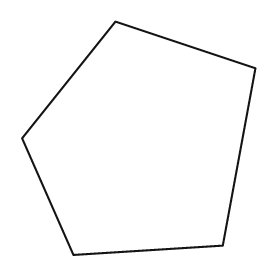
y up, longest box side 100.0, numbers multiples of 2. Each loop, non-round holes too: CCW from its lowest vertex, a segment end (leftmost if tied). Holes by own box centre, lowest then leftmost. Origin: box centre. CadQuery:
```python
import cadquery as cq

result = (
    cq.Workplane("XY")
    .moveTo(-28.0, -50.0)
    .lineTo(36.0, -46.0)
    .lineTo(50.0, 30.0)
    .lineTo(-10.0, 50.0)
    .lineTo(-50.0, 0.0)
    .close()
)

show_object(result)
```